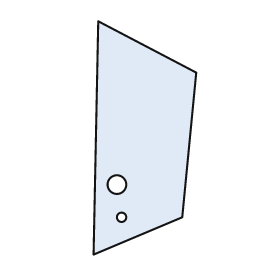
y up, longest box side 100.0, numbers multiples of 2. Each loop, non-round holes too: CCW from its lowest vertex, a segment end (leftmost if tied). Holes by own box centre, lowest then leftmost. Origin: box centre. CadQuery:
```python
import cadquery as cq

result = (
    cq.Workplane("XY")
    .moveTo(-22.0, -50.0)
    .lineTo(16.0, -34.0)
    .lineTo(22.0, 28.0)
    .lineTo(-20.0, 50.0)
    .close()
    .moveTo(-10.0, -34.0)
    .circle(2.0)
    .moveTo(-12.0, -20.0)
    .circle(4.0)
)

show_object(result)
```